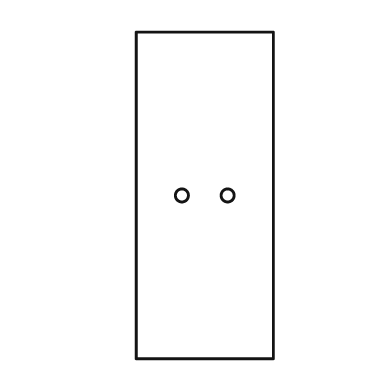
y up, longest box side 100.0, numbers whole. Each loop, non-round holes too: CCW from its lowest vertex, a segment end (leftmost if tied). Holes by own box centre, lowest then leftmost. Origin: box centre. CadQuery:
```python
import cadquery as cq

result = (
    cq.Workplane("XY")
    .moveTo(-21.0, -50.0)
    .lineTo(21.0, -50.0)
    .lineTo(21.0, 50.0)
    .lineTo(-21.0, 50.0)
    .close()
    .moveTo(-7.0, 0.0)
    .circle(2.0)
    .moveTo(7.0, 0.0)
    .circle(2.0)
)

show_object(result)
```